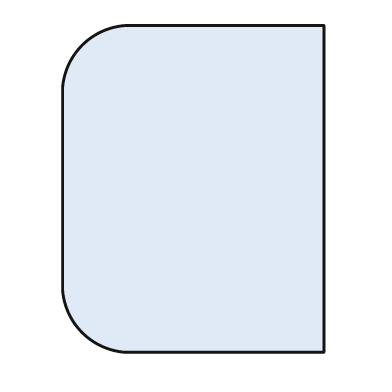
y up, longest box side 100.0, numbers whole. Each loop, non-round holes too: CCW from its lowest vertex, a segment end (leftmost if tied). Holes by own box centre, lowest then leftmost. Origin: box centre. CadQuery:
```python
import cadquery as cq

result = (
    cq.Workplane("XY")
    .moveTo(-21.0, -50.0)
    .lineTo(40.0, -50.0)
    .lineTo(40.0, 50.0)
    .lineTo(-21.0, 50.0)
    .threePointArc((-34.0, 44.0), (-40.0, 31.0))
    .lineTo(-40.0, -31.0)
    .threePointArc((-34.0, -44.0), (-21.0, -50.0))
    .close()
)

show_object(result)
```